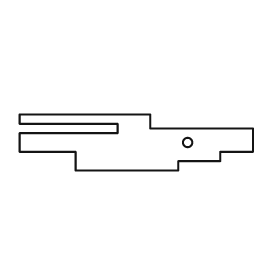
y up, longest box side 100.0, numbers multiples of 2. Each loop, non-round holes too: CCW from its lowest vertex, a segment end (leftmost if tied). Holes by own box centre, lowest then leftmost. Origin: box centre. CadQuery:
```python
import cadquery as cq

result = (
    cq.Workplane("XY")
    .moveTo(-26.0, -12.0)
    .lineTo(18.0, -12.0)
    .lineTo(18.0, -8.0)
    .lineTo(36.0, -8.0)
    .lineTo(36.0, -4.0)
    .lineTo(50.0, -4.0)
    .lineTo(50.0, 6.0)
    .lineTo(6.0, 6.0)
    .lineTo(6.0, 12.0)
    .lineTo(-50.0, 12.0)
    .lineTo(-50.0, 8.0)
    .lineTo(-8.0, 8.0)
    .lineTo(-8.0, 4.0)
    .lineTo(-50.0, 4.0)
    .lineTo(-50.0, -4.0)
    .lineTo(-26.0, -4.0)
    .close()
    .moveTo(22.0, 0.0)
    .circle(2.0)
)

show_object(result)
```